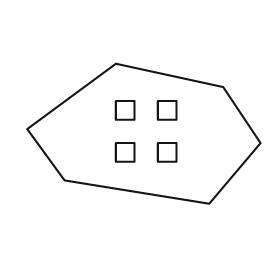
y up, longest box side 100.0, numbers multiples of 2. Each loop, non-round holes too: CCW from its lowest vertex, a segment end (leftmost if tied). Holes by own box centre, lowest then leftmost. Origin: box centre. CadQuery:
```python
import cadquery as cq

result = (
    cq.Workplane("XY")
    .moveTo(28.0, -30.0)
    .lineTo(50.0, -4.0)
    .lineTo(34.0, 20.0)
    .lineTo(-12.0, 30.0)
    .lineTo(-50.0, 2.0)
    .lineTo(-34.0, -20.0)
    .close()
    .moveTo(-12.0, -12.0)
    .lineTo(-4.0, -12.0)
    .lineTo(-4.0, -4.0)
    .lineTo(-12.0, -4.0)
    .close()
    .moveTo(6.0, -12.0)
    .lineTo(14.0, -12.0)
    .lineTo(14.0, -4.0)
    .lineTo(6.0, -4.0)
    .close()
    .moveTo(-12.0, 6.0)
    .lineTo(-4.0, 6.0)
    .lineTo(-4.0, 14.0)
    .lineTo(-12.0, 14.0)
    .close()
    .moveTo(6.0, 6.0)
    .lineTo(14.0, 6.0)
    .lineTo(14.0, 14.0)
    .lineTo(6.0, 14.0)
    .close()
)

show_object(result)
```